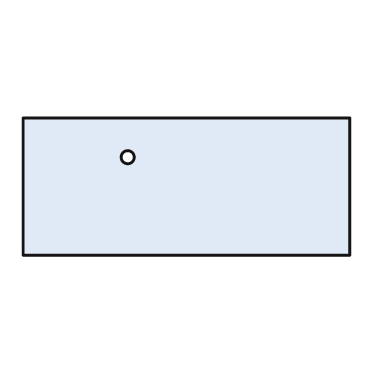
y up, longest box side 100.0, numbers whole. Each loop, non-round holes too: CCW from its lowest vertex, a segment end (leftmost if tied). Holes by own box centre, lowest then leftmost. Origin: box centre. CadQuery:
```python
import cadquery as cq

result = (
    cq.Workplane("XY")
    .moveTo(-50.0, -21.0)
    .lineTo(50.0, -21.0)
    .lineTo(50.0, 21.0)
    .lineTo(-50.0, 21.0)
    .close()
    .moveTo(-18.0, 9.0)
    .circle(2.0)
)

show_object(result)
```